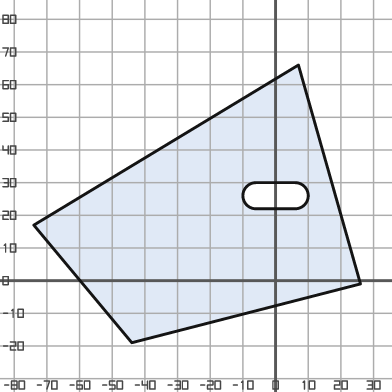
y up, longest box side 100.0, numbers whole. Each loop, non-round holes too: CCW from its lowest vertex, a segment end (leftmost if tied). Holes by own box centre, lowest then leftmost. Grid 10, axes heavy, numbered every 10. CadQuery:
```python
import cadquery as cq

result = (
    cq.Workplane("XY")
    .moveTo(-44.0, -19.0)
    .lineTo(26.0, -1.0)
    .lineTo(7.0, 66.0)
    .lineTo(-74.0, 17.0)
    .close()
    .moveTo(-6.0, 22.0)
    .lineTo(6.0, 22.0)
    .threePointArc((10.0, 26.0), (6.0, 30.0))
    .lineTo(-6.0, 30.0)
    .threePointArc((-10.0, 26.0), (-6.0, 22.0))
    .close()
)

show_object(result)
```